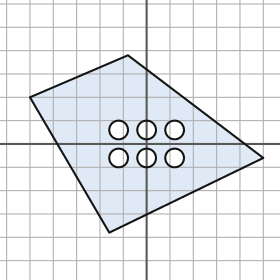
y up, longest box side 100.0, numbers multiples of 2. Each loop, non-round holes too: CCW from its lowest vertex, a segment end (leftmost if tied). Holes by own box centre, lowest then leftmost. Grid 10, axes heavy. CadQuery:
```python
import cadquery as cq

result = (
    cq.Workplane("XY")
    .moveTo(-16.0, -38.0)
    .lineTo(50.0, -6.0)
    .lineTo(-8.0, 38.0)
    .lineTo(-50.0, 20.0)
    .close()
    .moveTo(-12.0, -6.0)
    .circle(4.0)
    .moveTo(0.0, -6.0)
    .circle(4.0)
    .moveTo(12.0, -6.0)
    .circle(4.0)
    .moveTo(-12.0, 6.0)
    .circle(4.0)
    .moveTo(0.0, 6.0)
    .circle(4.0)
    .moveTo(12.0, 6.0)
    .circle(4.0)
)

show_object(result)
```